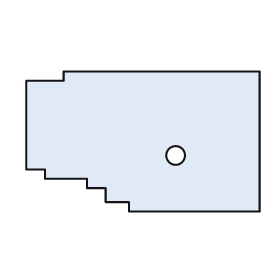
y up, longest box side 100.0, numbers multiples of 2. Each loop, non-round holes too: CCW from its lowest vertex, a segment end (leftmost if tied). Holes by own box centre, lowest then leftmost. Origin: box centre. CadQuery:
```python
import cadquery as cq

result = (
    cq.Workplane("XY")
    .moveTo(-6.0, -30.0)
    .lineTo(50.0, -30.0)
    .lineTo(50.0, 30.0)
    .lineTo(-34.0, 30.0)
    .lineTo(-34.0, 26.0)
    .lineTo(-50.0, 26.0)
    .lineTo(-50.0, -12.0)
    .lineTo(-42.0, -12.0)
    .lineTo(-42.0, -16.0)
    .lineTo(-24.0, -16.0)
    .lineTo(-24.0, -20.0)
    .lineTo(-16.0, -20.0)
    .lineTo(-16.0, -26.0)
    .lineTo(-6.0, -26.0)
    .close()
    .moveTo(14.0, -6.0)
    .circle(4.0)
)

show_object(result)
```